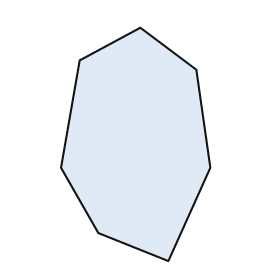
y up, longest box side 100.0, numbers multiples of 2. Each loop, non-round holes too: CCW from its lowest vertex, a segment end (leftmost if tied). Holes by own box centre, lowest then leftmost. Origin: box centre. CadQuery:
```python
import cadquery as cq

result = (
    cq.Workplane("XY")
    .moveTo(14.0, -50.0)
    .lineTo(32.0, -10.0)
    .lineTo(26.0, 32.0)
    .lineTo(2.0, 50.0)
    .lineTo(-24.0, 36.0)
    .lineTo(-32.0, -10.0)
    .lineTo(-16.0, -38.0)
    .close()
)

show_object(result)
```